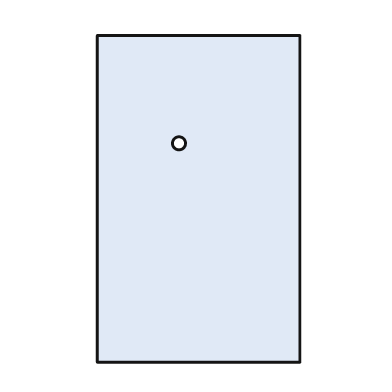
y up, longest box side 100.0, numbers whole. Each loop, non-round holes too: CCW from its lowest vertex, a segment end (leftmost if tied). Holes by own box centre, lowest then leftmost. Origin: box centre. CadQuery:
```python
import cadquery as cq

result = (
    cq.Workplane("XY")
    .moveTo(-31.0, -50.0)
    .lineTo(31.0, -50.0)
    .lineTo(31.0, 50.0)
    .lineTo(-31.0, 50.0)
    .close()
    .moveTo(-6.0, 17.0)
    .circle(2.0)
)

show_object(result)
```